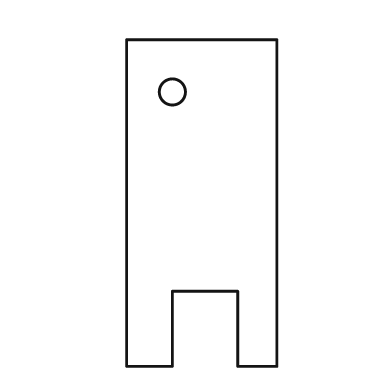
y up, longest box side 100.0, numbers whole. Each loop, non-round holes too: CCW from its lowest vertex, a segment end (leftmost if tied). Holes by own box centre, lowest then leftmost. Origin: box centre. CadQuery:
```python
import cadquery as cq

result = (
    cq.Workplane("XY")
    .moveTo(-23.0, -50.0)
    .lineTo(-9.0, -50.0)
    .lineTo(-9.0, -27.0)
    .lineTo(11.0, -27.0)
    .lineTo(11.0, -50.0)
    .lineTo(23.0, -50.0)
    .lineTo(23.0, 50.0)
    .lineTo(-23.0, 50.0)
    .close()
    .moveTo(-9.0, 34.0)
    .circle(4.0)
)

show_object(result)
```